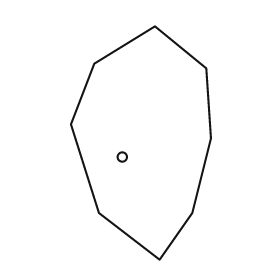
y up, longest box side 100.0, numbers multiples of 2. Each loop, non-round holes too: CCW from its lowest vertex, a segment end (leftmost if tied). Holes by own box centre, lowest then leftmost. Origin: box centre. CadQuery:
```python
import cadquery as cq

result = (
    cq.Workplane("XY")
    .moveTo(8.0, -50.0)
    .lineTo(22.0, -30.0)
    .lineTo(30.0, 2.0)
    .lineTo(28.0, 32.0)
    .lineTo(6.0, 50.0)
    .lineTo(-20.0, 34.0)
    .lineTo(-30.0, 8.0)
    .lineTo(-18.0, -30.0)
    .close()
    .moveTo(-8.0, -6.0)
    .circle(2.0)
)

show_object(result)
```